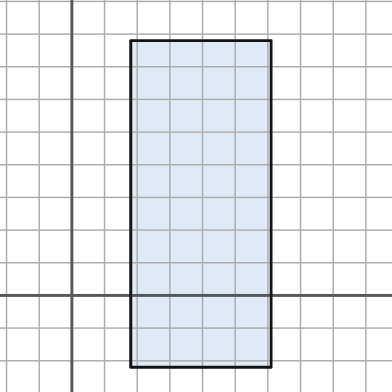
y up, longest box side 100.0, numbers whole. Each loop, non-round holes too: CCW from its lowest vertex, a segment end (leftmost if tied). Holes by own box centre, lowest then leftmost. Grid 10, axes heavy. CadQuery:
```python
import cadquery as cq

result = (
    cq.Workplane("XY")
    .moveTo(18.0, -22.0)
    .lineTo(61.0, -22.0)
    .lineTo(61.0, 78.0)
    .lineTo(18.0, 78.0)
    .close()
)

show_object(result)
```